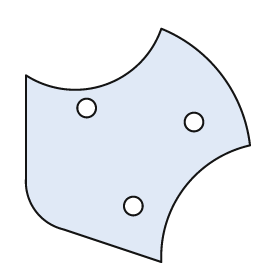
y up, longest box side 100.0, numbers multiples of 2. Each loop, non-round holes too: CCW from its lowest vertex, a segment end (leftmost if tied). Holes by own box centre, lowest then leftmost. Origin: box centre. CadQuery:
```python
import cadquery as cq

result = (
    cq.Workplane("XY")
    .moveTo(10.0, -50.0)
    .threePointArc((20.0, -18.0), (48.0, 0.0))
    .threePointArc((36.0, 30.0), (10.0, 50.0))
    .threePointArc((-14.0, 26.0), (-48.0, 30.0))
    .lineTo(-48.0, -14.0)
    .threePointArc((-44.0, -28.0), (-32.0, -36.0))
    .close()
    .moveTo(-2.0, -26.0)
    .circle(4.0)
    .moveTo(24.0, 10.0)
    .circle(4.0)
    .moveTo(-22.0, 16.0)
    .circle(4.0)
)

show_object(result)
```